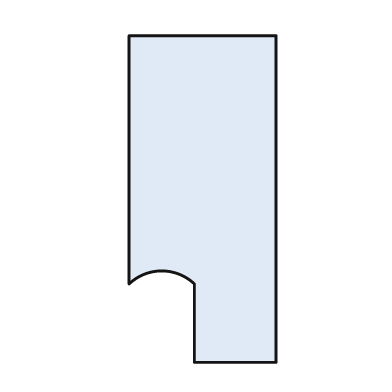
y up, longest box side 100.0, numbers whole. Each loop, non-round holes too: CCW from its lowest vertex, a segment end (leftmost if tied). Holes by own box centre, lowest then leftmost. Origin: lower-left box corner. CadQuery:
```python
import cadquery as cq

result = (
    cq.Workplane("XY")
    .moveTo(20.0, 0.0)
    .lineTo(45.0, 0.0)
    .lineTo(45.0, 100.0)
    .lineTo(0.0, 100.0)
    .lineTo(0.0, 24.0)
    .threePointArc((10.0, 28.0), (20.0, 24.0))
    .close()
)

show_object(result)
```